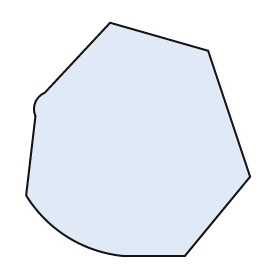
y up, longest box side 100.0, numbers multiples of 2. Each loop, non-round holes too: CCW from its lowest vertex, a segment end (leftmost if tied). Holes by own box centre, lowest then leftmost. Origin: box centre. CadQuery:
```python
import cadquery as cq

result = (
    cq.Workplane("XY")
    .moveTo(-6.0, -50.0)
    .lineTo(20.0, -50.0)
    .lineTo(48.0, -16.0)
    .lineTo(30.0, 38.0)
    .lineTo(-12.0, 50.0)
    .lineTo(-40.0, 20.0)
    .threePointArc((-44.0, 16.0), (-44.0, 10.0))
    .lineTo(-48.0, -24.0)
    .threePointArc((-30.0, -42.0), (-6.0, -50.0))
    .close()
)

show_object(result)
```